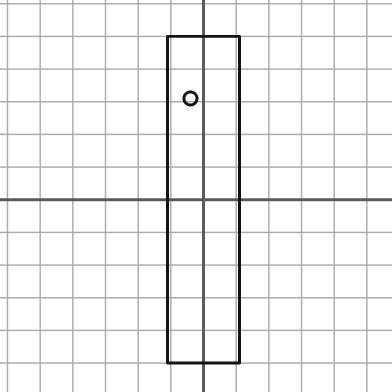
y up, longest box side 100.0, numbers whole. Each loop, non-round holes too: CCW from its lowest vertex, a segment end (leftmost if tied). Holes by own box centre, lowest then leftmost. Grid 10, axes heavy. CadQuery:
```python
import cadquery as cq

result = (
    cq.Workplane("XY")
    .moveTo(-11.0, -50.0)
    .lineTo(11.0, -50.0)
    .lineTo(11.0, 50.0)
    .lineTo(-11.0, 50.0)
    .close()
    .moveTo(-4.0, 31.0)
    .circle(2.0)
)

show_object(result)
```